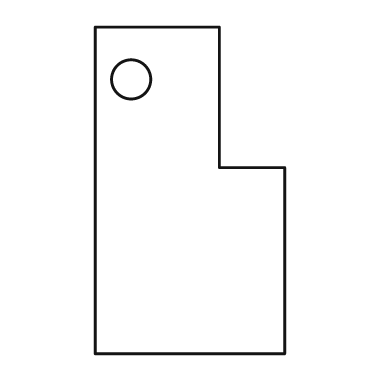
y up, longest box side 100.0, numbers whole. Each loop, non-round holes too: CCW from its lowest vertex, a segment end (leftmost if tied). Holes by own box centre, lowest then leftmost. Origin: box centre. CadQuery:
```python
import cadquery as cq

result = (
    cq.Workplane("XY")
    .moveTo(-29.0, -50.0)
    .lineTo(29.0, -50.0)
    .lineTo(29.0, 7.0)
    .lineTo(9.0, 7.0)
    .lineTo(9.0, 50.0)
    .lineTo(-29.0, 50.0)
    .close()
    .moveTo(-18.0, 34.0)
    .circle(6.0)
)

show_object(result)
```